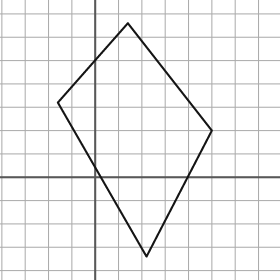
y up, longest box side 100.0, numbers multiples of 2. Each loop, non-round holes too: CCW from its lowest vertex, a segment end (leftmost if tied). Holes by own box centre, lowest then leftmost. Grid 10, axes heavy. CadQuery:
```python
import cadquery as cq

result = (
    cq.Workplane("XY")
    .moveTo(22.0, -34.0)
    .lineTo(50.0, 20.0)
    .lineTo(14.0, 66.0)
    .lineTo(-16.0, 32.0)
    .close()
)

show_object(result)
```